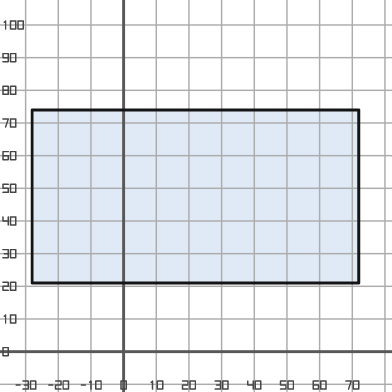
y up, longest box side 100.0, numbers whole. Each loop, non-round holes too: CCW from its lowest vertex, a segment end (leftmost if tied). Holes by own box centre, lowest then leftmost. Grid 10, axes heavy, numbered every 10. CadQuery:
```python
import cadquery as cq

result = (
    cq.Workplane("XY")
    .moveTo(-28.0, 21.0)
    .lineTo(72.0, 21.0)
    .lineTo(72.0, 74.0)
    .lineTo(-28.0, 74.0)
    .close()
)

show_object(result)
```